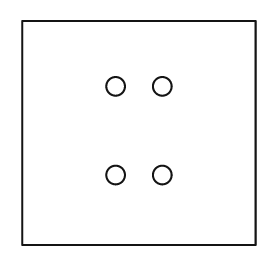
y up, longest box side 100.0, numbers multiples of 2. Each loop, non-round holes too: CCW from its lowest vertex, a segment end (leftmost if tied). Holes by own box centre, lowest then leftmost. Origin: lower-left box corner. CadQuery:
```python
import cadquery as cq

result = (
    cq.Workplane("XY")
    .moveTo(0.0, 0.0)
    .lineTo(100.0, 0.0)
    .lineTo(100.0, 96.0)
    .lineTo(0.0, 96.0)
    .close()
    .moveTo(40.0, 30.0)
    .circle(4.0)
    .moveTo(60.0, 30.0)
    .circle(4.0)
    .moveTo(40.0, 68.0)
    .circle(4.0)
    .moveTo(60.0, 68.0)
    .circle(4.0)
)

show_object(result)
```